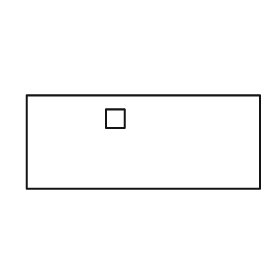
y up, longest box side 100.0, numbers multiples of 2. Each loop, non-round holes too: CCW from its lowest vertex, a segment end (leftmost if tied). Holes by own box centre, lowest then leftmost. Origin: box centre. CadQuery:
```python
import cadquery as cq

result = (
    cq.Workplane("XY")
    .moveTo(-50.0, -20.0)
    .lineTo(50.0, -20.0)
    .lineTo(50.0, 20.0)
    .lineTo(-50.0, 20.0)
    .close()
    .moveTo(-16.0, 6.0)
    .lineTo(-8.0, 6.0)
    .lineTo(-8.0, 14.0)
    .lineTo(-16.0, 14.0)
    .close()
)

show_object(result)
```